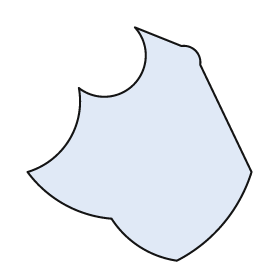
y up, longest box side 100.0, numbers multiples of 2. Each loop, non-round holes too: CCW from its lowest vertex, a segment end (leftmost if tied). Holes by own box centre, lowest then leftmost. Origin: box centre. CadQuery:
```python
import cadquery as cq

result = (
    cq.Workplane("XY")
    .moveTo(16.0, -50.0)
    .threePointArc((36.0, -34.0), (48.0, -12.0))
    .lineTo(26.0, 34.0)
    .threePointArc((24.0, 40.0), (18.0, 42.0))
    .lineTo(-2.0, 50.0)
    .threePointArc((-2.0, 26.0), (-26.0, 24.0))
    .threePointArc((-30.0, 2.0), (-48.0, -12.0))
    .threePointArc((-32.0, -26.0), (-12.0, -32.0))
    .threePointArc((0.0, -44.0), (16.0, -50.0))
    .close()
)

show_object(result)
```